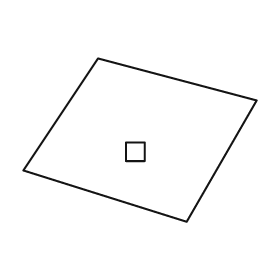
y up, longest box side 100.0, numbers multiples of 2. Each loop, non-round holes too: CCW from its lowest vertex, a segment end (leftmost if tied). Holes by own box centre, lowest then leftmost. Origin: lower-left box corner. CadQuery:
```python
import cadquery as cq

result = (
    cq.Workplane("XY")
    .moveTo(70.0, 0.0)
    .lineTo(100.0, 52.0)
    .lineTo(32.0, 70.0)
    .lineTo(0.0, 22.0)
    .close()
    .moveTo(44.0, 26.0)
    .lineTo(52.0, 26.0)
    .lineTo(52.0, 34.0)
    .lineTo(44.0, 34.0)
    .close()
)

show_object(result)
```